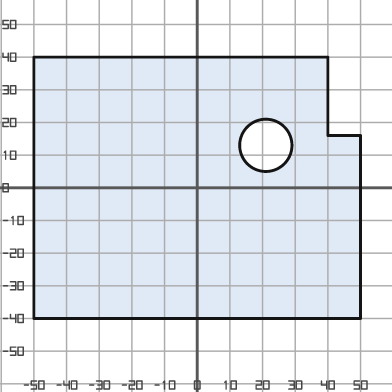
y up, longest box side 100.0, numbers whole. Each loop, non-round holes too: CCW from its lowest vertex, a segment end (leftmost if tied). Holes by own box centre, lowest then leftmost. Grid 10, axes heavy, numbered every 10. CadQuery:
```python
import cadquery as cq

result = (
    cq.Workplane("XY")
    .moveTo(-50.0, -40.0)
    .lineTo(50.0, -40.0)
    .lineTo(50.0, 16.0)
    .lineTo(40.0, 16.0)
    .lineTo(40.0, 40.0)
    .lineTo(-50.0, 40.0)
    .close()
    .moveTo(21.0, 13.0)
    .circle(8.0)
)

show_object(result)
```